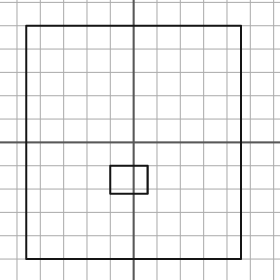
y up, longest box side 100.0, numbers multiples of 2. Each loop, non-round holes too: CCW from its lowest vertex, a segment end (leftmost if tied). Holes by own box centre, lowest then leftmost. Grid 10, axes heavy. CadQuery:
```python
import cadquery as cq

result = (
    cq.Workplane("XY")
    .moveTo(-46.0, -50.0)
    .lineTo(46.0, -50.0)
    .lineTo(46.0, 50.0)
    .lineTo(-46.0, 50.0)
    .close()
    .moveTo(-10.0, -22.0)
    .lineTo(6.0, -22.0)
    .lineTo(6.0, -10.0)
    .lineTo(-10.0, -10.0)
    .close()
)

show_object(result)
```